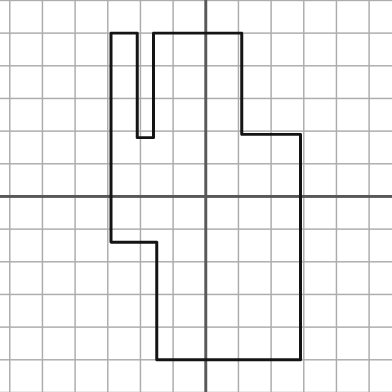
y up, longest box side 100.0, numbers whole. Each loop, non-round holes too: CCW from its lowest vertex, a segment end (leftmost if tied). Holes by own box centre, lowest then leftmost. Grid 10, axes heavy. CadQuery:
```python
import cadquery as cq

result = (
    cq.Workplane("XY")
    .moveTo(-15.0, -50.0)
    .lineTo(29.0, -50.0)
    .lineTo(29.0, 19.0)
    .lineTo(11.0, 19.0)
    .lineTo(11.0, 50.0)
    .lineTo(-16.0, 50.0)
    .lineTo(-16.0, 18.0)
    .lineTo(-21.0, 18.0)
    .lineTo(-21.0, 50.0)
    .lineTo(-29.0, 50.0)
    .lineTo(-29.0, -14.0)
    .lineTo(-15.0, -14.0)
    .close()
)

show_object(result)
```